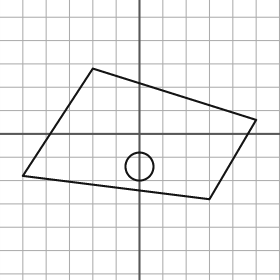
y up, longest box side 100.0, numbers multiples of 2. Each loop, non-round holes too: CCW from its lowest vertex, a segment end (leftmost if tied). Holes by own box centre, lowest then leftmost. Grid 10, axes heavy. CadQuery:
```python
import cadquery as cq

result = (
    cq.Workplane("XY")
    .moveTo(30.0, -28.0)
    .lineTo(50.0, 6.0)
    .lineTo(-20.0, 28.0)
    .lineTo(-50.0, -18.0)
    .close()
    .moveTo(0.0, -14.0)
    .circle(6.0)
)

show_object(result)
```